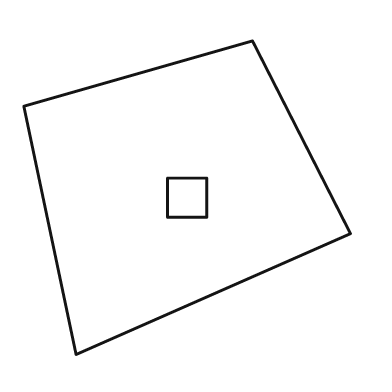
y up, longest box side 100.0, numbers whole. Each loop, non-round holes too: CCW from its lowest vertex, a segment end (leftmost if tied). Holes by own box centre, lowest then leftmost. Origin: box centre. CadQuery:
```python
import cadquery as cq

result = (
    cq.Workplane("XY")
    .moveTo(-34.0, -48.0)
    .lineTo(50.0, -11.0)
    .lineTo(20.0, 48.0)
    .lineTo(-50.0, 28.0)
    .close()
    .moveTo(-6.0, -6.0)
    .lineTo(6.0, -6.0)
    .lineTo(6.0, 6.0)
    .lineTo(-6.0, 6.0)
    .close()
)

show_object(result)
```